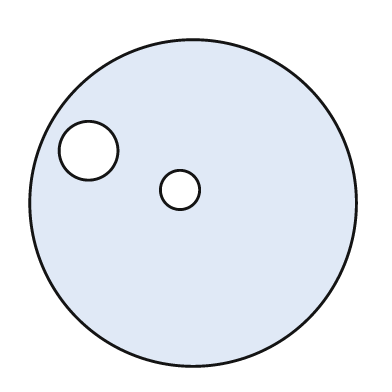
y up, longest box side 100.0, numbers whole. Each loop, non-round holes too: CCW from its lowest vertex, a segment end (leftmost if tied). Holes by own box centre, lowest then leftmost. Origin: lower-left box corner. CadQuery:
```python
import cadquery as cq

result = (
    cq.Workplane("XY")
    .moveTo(50.0, 50.0)
    .circle(50.0)
    .moveTo(46.0, 54.0)
    .circle(6.0)
    .moveTo(18.0, 66.0)
    .circle(9.0)
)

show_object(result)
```